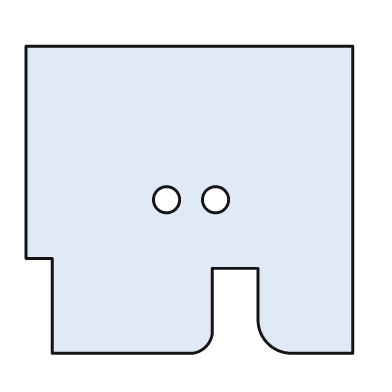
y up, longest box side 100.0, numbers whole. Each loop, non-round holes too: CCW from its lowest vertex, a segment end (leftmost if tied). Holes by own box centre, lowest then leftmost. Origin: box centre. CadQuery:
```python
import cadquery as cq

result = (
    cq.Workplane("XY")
    .moveTo(-42.0, -47.0)
    .lineTo(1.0, -47.0)
    .threePointArc((5.0, -45.0), (7.0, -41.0))
    .lineTo(7.0, -21.0)
    .lineTo(21.0, -21.0)
    .lineTo(21.0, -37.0)
    .threePointArc((24.0, -44.0), (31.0, -47.0))
    .lineTo(50.0, -47.0)
    .lineTo(50.0, 47.0)
    .lineTo(-50.0, 47.0)
    .lineTo(-50.0, -18.0)
    .lineTo(-42.0, -18.0)
    .close()
    .moveTo(-7.0, 0.0)
    .circle(4.0)
    .moveTo(8.0, 0.0)
    .circle(4.0)
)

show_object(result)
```